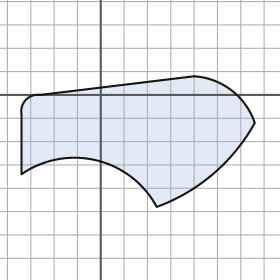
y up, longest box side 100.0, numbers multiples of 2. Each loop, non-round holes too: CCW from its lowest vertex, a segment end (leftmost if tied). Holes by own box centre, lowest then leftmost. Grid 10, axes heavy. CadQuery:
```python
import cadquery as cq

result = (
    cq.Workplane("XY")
    .moveTo(24.0, -48.0)
    .threePointArc((48.0, -34.0), (66.0, -12.0))
    .threePointArc((56.0, 2.0), (40.0, 8.0))
    .lineTo(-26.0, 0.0)
    .threePointArc((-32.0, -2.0), (-34.0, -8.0))
    .lineTo(-34.0, -34.0)
    .threePointArc((-2.0, -28.0), (24.0, -48.0))
    .close()
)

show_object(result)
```